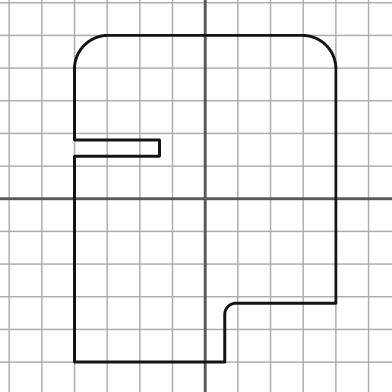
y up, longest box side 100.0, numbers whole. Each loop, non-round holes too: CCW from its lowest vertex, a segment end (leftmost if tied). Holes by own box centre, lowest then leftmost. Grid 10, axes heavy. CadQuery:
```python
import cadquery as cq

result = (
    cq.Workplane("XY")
    .moveTo(-40.0, -50.0)
    .lineTo(6.0, -50.0)
    .lineTo(6.0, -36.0)
    .threePointArc((7.0, -33.0), (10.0, -32.0))
    .lineTo(40.0, -32.0)
    .lineTo(40.0, 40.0)
    .threePointArc((37.0, 47.0), (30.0, 50.0))
    .lineTo(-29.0, 50.0)
    .threePointArc((-37.0, 47.0), (-40.0, 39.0))
    .lineTo(-40.0, 18.0)
    .lineTo(-14.0, 18.0)
    .lineTo(-14.0, 13.0)
    .lineTo(-40.0, 13.0)
    .close()
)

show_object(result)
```